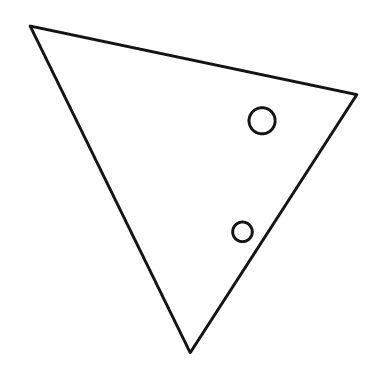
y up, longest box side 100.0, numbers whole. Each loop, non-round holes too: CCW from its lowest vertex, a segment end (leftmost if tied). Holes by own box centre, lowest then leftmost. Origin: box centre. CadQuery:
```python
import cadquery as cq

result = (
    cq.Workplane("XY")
    .moveTo(-1.0, -50.0)
    .lineTo(50.0, 29.0)
    .lineTo(-50.0, 50.0)
    .close()
    .moveTo(15.0, -13.0)
    .circle(3.0)
    .moveTo(21.0, 21.0)
    .circle(4.0)
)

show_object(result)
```